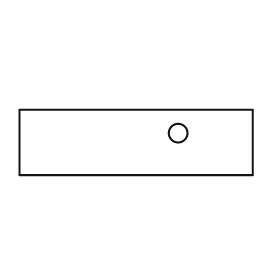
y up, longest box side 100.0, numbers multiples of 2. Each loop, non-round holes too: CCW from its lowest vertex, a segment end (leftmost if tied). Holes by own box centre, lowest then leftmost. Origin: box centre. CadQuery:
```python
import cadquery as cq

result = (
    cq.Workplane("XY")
    .moveTo(-50.0, -14.0)
    .lineTo(50.0, -14.0)
    .lineTo(50.0, 14.0)
    .lineTo(-50.0, 14.0)
    .close()
    .moveTo(18.0, 4.0)
    .circle(4.0)
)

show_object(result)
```